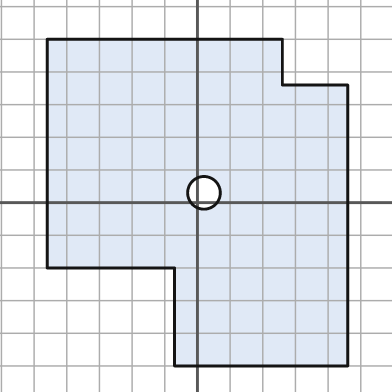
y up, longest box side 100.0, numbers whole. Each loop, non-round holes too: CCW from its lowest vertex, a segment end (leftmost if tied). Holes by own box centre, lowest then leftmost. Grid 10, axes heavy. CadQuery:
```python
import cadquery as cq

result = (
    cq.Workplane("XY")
    .moveTo(-7.0, -50.0)
    .lineTo(46.0, -50.0)
    .lineTo(46.0, 36.0)
    .lineTo(26.0, 36.0)
    .lineTo(26.0, 50.0)
    .lineTo(-46.0, 50.0)
    .lineTo(-46.0, -20.0)
    .lineTo(-7.0, -20.0)
    .close()
    .moveTo(2.0, 3.0)
    .circle(5.0)
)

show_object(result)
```